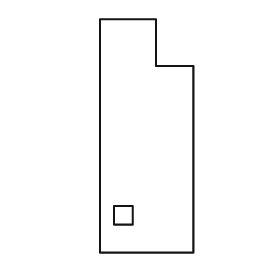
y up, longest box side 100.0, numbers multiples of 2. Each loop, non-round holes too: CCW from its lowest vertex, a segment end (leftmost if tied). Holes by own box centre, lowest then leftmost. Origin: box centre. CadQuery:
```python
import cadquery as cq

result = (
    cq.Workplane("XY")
    .moveTo(-20.0, -50.0)
    .lineTo(20.0, -50.0)
    .lineTo(20.0, 30.0)
    .lineTo(4.0, 30.0)
    .lineTo(4.0, 50.0)
    .lineTo(-20.0, 50.0)
    .close()
    .moveTo(-14.0, -38.0)
    .lineTo(-6.0, -38.0)
    .lineTo(-6.0, -30.0)
    .lineTo(-14.0, -30.0)
    .close()
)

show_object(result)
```